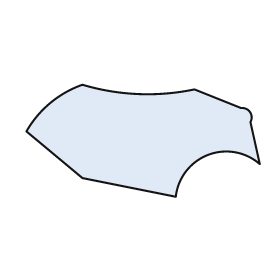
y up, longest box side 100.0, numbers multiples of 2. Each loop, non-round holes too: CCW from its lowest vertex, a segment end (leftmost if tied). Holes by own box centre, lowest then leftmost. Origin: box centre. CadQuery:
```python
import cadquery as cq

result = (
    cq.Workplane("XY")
    .moveTo(14.0, -24.0)
    .threePointArc((28.0, -6.0), (50.0, -10.0))
    .lineTo(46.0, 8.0)
    .threePointArc((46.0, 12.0), (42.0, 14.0))
    .lineTo(22.0, 22.0)
    .threePointArc((-2.0, 20.0), (-26.0, 24.0))
    .threePointArc((-40.0, 16.0), (-50.0, 4.0))
    .lineTo(-26.0, -16.0)
    .close()
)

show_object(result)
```